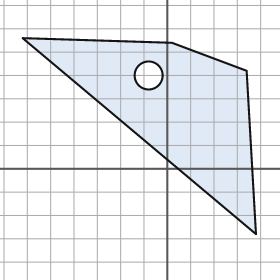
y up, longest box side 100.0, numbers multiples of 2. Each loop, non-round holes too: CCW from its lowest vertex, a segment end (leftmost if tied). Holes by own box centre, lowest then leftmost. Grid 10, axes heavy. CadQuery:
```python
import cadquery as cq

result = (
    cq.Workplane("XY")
    .moveTo(38.0, -28.0)
    .lineTo(34.0, 42.0)
    .lineTo(2.0, 54.0)
    .lineTo(-62.0, 56.0)
    .close()
    .moveTo(-8.0, 40.0)
    .circle(6.0)
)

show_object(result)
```